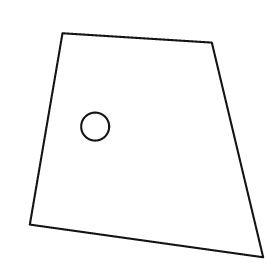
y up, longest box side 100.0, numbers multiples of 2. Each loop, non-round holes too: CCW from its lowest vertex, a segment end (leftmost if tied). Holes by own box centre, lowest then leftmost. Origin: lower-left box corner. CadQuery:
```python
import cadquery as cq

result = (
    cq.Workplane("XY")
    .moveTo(100.0, 0.0)
    .lineTo(78.0, 92.0)
    .lineTo(14.0, 96.0)
    .lineTo(0.0, 14.0)
    .close()
    .moveTo(28.0, 56.0)
    .circle(6.0)
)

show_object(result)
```